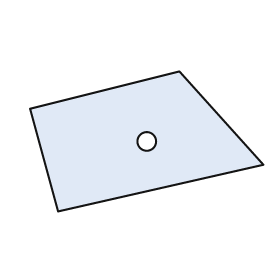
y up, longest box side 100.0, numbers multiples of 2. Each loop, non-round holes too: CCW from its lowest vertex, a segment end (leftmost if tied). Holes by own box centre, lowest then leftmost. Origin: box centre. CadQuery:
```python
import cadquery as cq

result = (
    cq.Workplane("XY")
    .moveTo(-38.0, -30.0)
    .lineTo(50.0, -10.0)
    .lineTo(14.0, 30.0)
    .lineTo(-50.0, 14.0)
    .close()
    .moveTo(0.0, 0.0)
    .circle(4.0)
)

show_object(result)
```